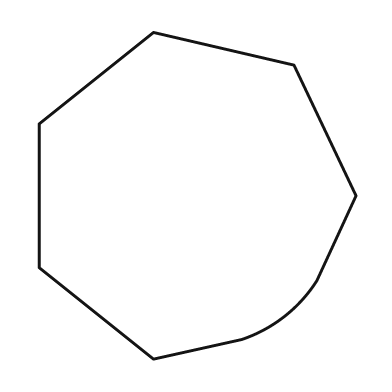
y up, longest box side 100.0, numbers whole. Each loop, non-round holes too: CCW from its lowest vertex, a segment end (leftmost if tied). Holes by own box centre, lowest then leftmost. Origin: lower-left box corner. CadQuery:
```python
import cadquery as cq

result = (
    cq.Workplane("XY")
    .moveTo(35.0, 0.0)
    .lineTo(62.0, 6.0)
    .threePointArc((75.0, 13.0), (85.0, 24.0))
    .lineTo(97.0, 50.0)
    .lineTo(78.0, 90.0)
    .lineTo(35.0, 100.0)
    .lineTo(0.0, 72.0)
    .lineTo(0.0, 28.0)
    .close()
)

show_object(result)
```